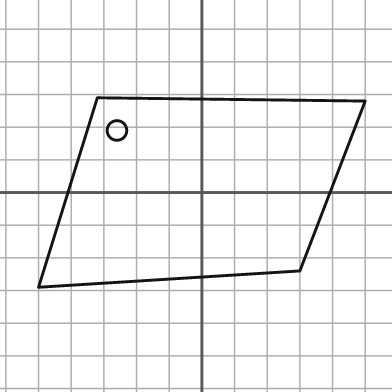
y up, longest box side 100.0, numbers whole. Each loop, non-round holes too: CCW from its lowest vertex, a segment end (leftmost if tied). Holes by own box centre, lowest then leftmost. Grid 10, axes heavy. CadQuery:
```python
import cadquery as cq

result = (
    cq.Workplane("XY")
    .moveTo(-50.0, -29.0)
    .lineTo(30.0, -24.0)
    .lineTo(50.0, 28.0)
    .lineTo(-32.0, 29.0)
    .close()
    .moveTo(-26.0, 19.0)
    .circle(3.0)
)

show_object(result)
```